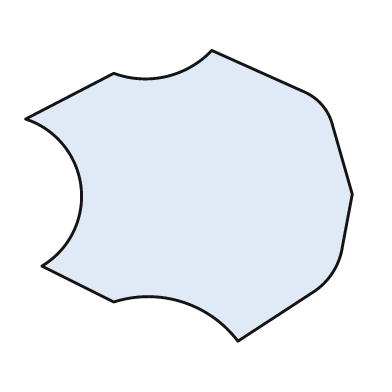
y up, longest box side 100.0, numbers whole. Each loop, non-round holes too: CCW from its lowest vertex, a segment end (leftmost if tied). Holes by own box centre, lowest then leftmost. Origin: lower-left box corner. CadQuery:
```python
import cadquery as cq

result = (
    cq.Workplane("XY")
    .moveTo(65.0, 0.0)
    .lineTo(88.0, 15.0)
    .threePointArc((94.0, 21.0), (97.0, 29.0))
    .lineTo(100.0, 45.0)
    .lineTo(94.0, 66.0)
    .threePointArc((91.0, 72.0), (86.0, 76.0))
    .lineTo(57.0, 89.0)
    .threePointArc((43.0, 81.0), (27.0, 82.0))
    .lineTo(0.0, 68.0)
    .threePointArc((17.0, 47.0), (5.0, 23.0))
    .lineTo(27.0, 12.0)
    .threePointArc((48.0, 12.0), (65.0, 0.0))
    .close()
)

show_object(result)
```